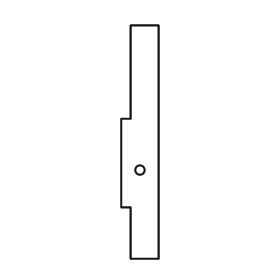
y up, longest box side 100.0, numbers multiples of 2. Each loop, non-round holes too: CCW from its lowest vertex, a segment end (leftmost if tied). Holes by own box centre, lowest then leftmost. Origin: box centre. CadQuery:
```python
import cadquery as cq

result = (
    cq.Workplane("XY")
    .moveTo(-4.0, -50.0)
    .lineTo(8.0, -50.0)
    .lineTo(8.0, 50.0)
    .lineTo(-4.0, 50.0)
    .lineTo(-4.0, 10.0)
    .lineTo(-8.0, 10.0)
    .lineTo(-8.0, -28.0)
    .lineTo(-4.0, -28.0)
    .close()
    .moveTo(0.0, -12.0)
    .circle(2.0)
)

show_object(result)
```